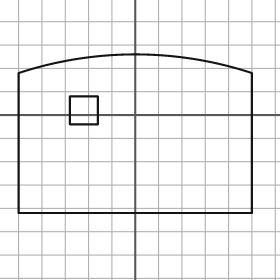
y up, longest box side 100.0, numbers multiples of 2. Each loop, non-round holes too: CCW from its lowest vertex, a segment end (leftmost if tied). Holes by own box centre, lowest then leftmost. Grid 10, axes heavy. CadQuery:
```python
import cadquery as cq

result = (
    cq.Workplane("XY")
    .moveTo(-50.0, -42.0)
    .lineTo(50.0, -42.0)
    .lineTo(50.0, 18.0)
    .threePointArc((0.0, 26.0), (-50.0, 18.0))
    .close()
    .moveTo(-28.0, -4.0)
    .lineTo(-16.0, -4.0)
    .lineTo(-16.0, 8.0)
    .lineTo(-28.0, 8.0)
    .close()
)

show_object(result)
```